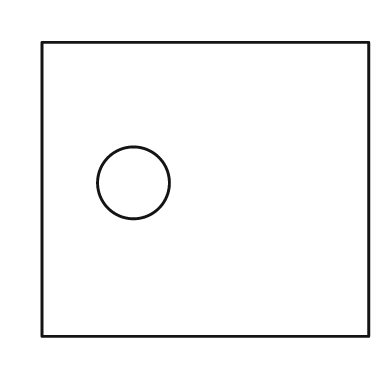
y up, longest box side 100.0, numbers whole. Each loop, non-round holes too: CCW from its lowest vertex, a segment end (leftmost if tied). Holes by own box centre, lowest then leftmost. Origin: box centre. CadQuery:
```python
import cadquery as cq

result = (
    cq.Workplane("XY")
    .moveTo(-50.0, -45.0)
    .lineTo(50.0, -45.0)
    .lineTo(50.0, 45.0)
    .lineTo(-50.0, 45.0)
    .close()
    .moveTo(-22.0, 2.0)
    .circle(11.0)
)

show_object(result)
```